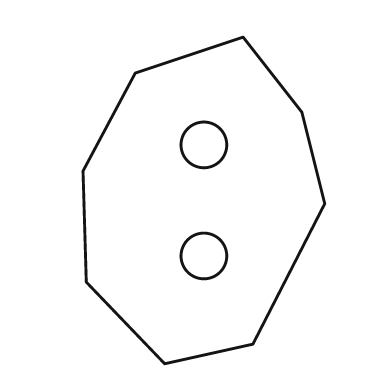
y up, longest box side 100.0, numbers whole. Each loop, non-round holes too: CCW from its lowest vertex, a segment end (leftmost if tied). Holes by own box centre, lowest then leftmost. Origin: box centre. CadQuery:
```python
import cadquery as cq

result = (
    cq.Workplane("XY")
    .moveTo(-12.0, -50.0)
    .lineTo(15.0, -44.0)
    .lineTo(37.0, -1.0)
    .lineTo(30.0, 27.0)
    .lineTo(12.0, 50.0)
    .lineTo(-21.0, 39.0)
    .lineTo(-37.0, 9.0)
    .lineTo(-36.0, -25.0)
    .close()
    .moveTo(0.0, -17.0)
    .circle(7.0)
    .moveTo(0.0, 17.0)
    .circle(7.0)
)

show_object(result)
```